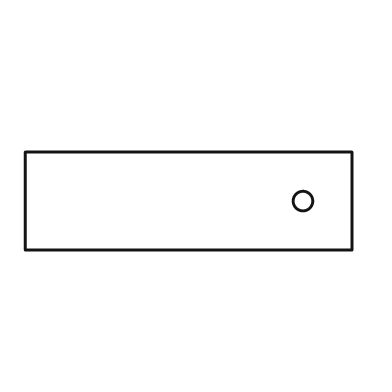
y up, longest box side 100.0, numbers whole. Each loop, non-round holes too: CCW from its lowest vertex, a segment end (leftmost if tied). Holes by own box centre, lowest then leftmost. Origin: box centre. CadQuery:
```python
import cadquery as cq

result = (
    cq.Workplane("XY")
    .moveTo(-50.0, -15.0)
    .lineTo(50.0, -15.0)
    .lineTo(50.0, 15.0)
    .lineTo(-50.0, 15.0)
    .close()
    .moveTo(35.0, 0.0)
    .circle(3.0)
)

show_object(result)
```